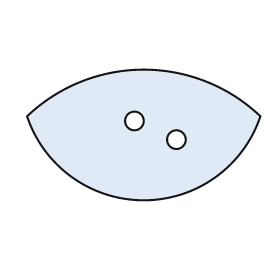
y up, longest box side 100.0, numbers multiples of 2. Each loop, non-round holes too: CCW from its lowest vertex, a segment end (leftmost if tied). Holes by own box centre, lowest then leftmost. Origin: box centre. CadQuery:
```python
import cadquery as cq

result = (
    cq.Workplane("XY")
    .moveTo(-50.0, 8.0)
    .threePointArc((0.0, -28.0), (50.0, 8.0))
    .threePointArc((0.0, 28.0), (-50.0, 8.0))
    .close()
    .moveTo(14.0, -2.0)
    .circle(4.0)
    .moveTo(-4.0, 6.0)
    .circle(4.0)
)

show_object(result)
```